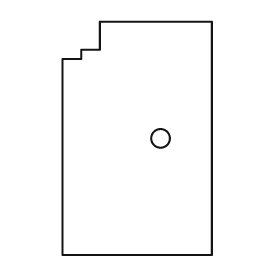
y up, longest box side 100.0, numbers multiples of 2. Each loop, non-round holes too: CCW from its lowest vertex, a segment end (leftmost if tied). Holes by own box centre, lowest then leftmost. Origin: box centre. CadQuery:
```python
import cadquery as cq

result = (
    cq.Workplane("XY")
    .moveTo(-32.0, -50.0)
    .lineTo(32.0, -50.0)
    .lineTo(32.0, 50.0)
    .lineTo(-16.0, 50.0)
    .lineTo(-16.0, 38.0)
    .lineTo(-24.0, 38.0)
    .lineTo(-24.0, 34.0)
    .lineTo(-32.0, 34.0)
    .close()
    .moveTo(10.0, 0.0)
    .circle(4.0)
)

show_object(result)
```